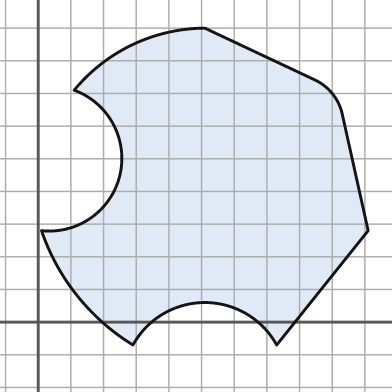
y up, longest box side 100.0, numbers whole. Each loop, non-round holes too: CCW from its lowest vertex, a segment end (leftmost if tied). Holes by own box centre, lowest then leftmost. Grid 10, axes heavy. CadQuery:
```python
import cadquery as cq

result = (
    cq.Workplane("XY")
    .moveTo(29.0, -7.0)
    .threePointArc((51.0, 6.0), (73.0, -7.0))
    .lineTo(101.0, 28.0)
    .lineTo(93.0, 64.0)
    .threePointArc((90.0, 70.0), (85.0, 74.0))
    .lineTo(51.0, 90.0)
    .threePointArc((29.0, 85.0), (11.0, 71.0))
    .threePointArc((25.0, 45.0), (1.0, 28.0))
    .threePointArc((12.0, 8.0), (29.0, -7.0))
    .close()
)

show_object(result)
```